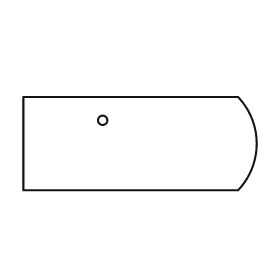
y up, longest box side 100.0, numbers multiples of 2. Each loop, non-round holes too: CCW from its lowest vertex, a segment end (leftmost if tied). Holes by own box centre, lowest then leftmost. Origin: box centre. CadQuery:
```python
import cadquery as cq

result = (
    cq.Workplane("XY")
    .moveTo(-50.0, -20.0)
    .lineTo(42.0, -20.0)
    .threePointArc((50.0, 0.0), (42.0, 20.0))
    .lineTo(-50.0, 20.0)
    .close()
    .moveTo(-16.0, 10.0)
    .circle(2.0)
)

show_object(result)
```